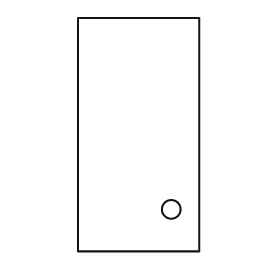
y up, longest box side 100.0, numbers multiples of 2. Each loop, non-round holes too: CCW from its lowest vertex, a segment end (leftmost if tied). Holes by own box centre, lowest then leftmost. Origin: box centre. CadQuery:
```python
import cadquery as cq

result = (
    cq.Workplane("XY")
    .moveTo(-26.0, -50.0)
    .lineTo(26.0, -50.0)
    .lineTo(26.0, 50.0)
    .lineTo(-26.0, 50.0)
    .close()
    .moveTo(14.0, -32.0)
    .circle(4.0)
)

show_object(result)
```